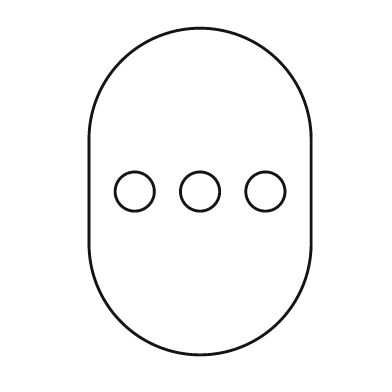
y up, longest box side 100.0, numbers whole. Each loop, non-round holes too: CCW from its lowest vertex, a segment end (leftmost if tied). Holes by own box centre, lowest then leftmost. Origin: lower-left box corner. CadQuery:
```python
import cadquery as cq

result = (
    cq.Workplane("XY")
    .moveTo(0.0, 34.0)
    .threePointArc((34.0, 0.0), (68.0, 34.0))
    .lineTo(68.0, 66.0)
    .threePointArc((34.0, 100.0), (0.0, 66.0))
    .close()
    .moveTo(14.0, 50.0)
    .circle(6.0)
    .moveTo(34.0, 50.0)
    .circle(6.0)
    .moveTo(54.0, 50.0)
    .circle(6.0)
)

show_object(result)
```